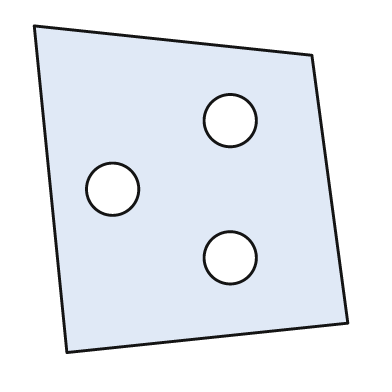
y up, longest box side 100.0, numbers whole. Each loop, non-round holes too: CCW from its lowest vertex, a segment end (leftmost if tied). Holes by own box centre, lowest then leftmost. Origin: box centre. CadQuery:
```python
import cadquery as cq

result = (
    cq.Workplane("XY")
    .moveTo(-38.0, -50.0)
    .lineTo(48.0, -41.0)
    .lineTo(37.0, 41.0)
    .lineTo(-48.0, 50.0)
    .close()
    .moveTo(12.0, -21.0)
    .circle(8.0)
    .moveTo(-24.0, 0.0)
    .circle(8.0)
    .moveTo(12.0, 21.0)
    .circle(8.0)
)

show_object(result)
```